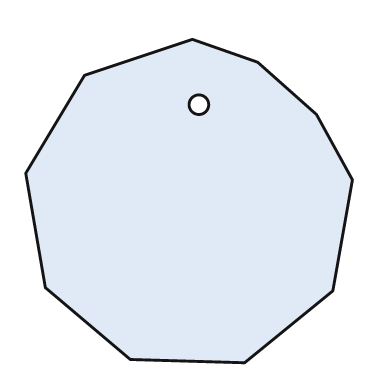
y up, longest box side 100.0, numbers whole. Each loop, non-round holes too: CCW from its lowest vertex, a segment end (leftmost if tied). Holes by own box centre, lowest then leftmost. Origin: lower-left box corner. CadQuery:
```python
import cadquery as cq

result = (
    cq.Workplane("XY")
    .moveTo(67.0, 0.0)
    .lineTo(94.0, 22.0)
    .lineTo(100.0, 56.0)
    .lineTo(89.0, 76.0)
    .lineTo(71.0, 92.0)
    .lineTo(51.0, 99.0)
    .lineTo(18.0, 88.0)
    .lineTo(0.0, 58.0)
    .lineTo(6.0, 23.0)
    .lineTo(32.0, 1.0)
    .close()
    .moveTo(53.0, 79.0)
    .circle(3.0)
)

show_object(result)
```